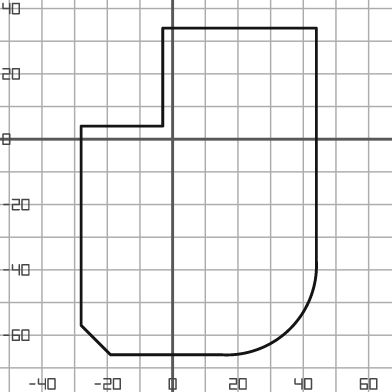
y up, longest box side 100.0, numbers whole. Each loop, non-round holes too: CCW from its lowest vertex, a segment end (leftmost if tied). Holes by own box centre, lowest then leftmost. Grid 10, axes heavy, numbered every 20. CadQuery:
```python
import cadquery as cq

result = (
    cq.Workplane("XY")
    .moveTo(-19.0, -66.0)
    .lineTo(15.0, -66.0)
    .threePointArc((36.0, -58.0), (44.0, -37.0))
    .lineTo(44.0, 34.0)
    .lineTo(-3.0, 34.0)
    .lineTo(-3.0, 4.0)
    .lineTo(-28.0, 4.0)
    .lineTo(-28.0, -57.0)
    .close()
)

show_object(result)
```